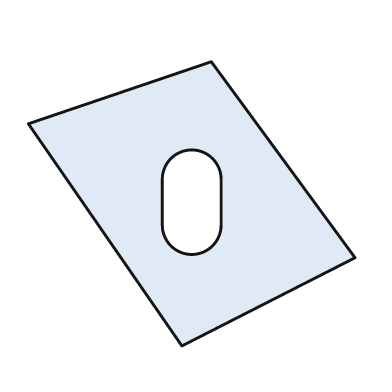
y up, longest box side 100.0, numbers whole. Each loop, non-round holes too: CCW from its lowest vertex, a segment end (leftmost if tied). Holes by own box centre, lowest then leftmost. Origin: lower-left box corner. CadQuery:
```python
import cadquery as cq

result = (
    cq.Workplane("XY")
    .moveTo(47.0, 0.0)
    .lineTo(100.0, 27.0)
    .lineTo(56.0, 87.0)
    .lineTo(0.0, 68.0)
    .close()
    .moveTo(41.0, 37.0)
    .threePointArc((50.0, 28.0), (59.0, 37.0))
    .lineTo(59.0, 51.0)
    .threePointArc((50.0, 60.0), (41.0, 51.0))
    .close()
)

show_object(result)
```